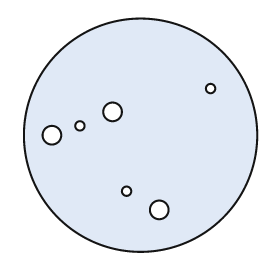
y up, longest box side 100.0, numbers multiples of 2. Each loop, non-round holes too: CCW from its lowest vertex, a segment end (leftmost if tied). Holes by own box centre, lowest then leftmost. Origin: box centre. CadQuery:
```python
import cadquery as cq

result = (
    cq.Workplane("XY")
    .moveTo(0.0, 0.0)
    .circle(50.0)
    .moveTo(8.0, -32.0)
    .circle(4.0)
    .moveTo(-6.0, -24.0)
    .circle(2.0)
    .moveTo(-38.0, 0.0)
    .circle(4.0)
    .moveTo(-26.0, 4.0)
    .circle(2.0)
    .moveTo(-12.0, 10.0)
    .circle(4.0)
    .moveTo(30.0, 20.0)
    .circle(2.0)
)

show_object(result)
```